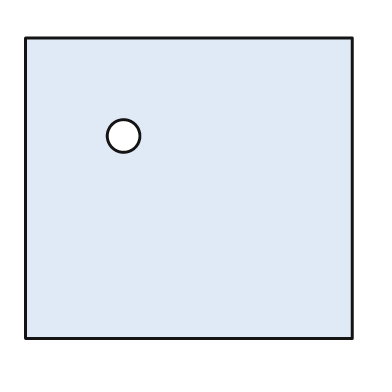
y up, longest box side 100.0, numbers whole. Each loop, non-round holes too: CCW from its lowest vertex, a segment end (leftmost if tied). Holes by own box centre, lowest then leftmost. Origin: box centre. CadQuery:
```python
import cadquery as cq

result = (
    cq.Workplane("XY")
    .moveTo(-50.0, -46.0)
    .lineTo(50.0, -46.0)
    .lineTo(50.0, 46.0)
    .lineTo(-50.0, 46.0)
    .close()
    .moveTo(-20.0, 16.0)
    .circle(5.0)
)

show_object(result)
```